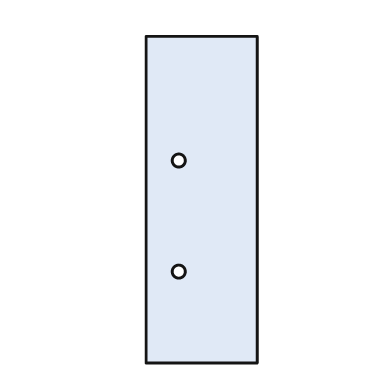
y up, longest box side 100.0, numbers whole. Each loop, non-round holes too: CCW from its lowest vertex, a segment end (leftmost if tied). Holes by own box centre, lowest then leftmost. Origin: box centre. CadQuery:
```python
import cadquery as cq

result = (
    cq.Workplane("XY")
    .moveTo(-17.0, -50.0)
    .lineTo(17.0, -50.0)
    .lineTo(17.0, 50.0)
    .lineTo(-17.0, 50.0)
    .close()
    .moveTo(-7.0, -22.0)
    .circle(2.0)
    .moveTo(-7.0, 12.0)
    .circle(2.0)
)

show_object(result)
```